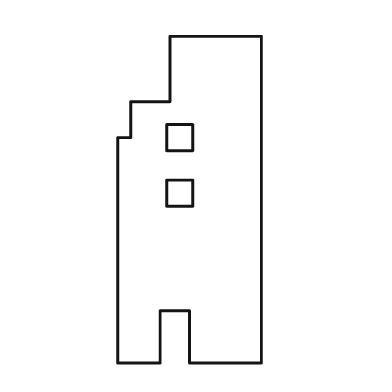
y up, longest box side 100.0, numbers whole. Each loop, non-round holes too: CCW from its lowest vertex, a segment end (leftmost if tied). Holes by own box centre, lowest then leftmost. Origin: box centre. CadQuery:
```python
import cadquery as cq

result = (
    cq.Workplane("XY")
    .moveTo(-22.0, -50.0)
    .lineTo(-9.0, -50.0)
    .lineTo(-9.0, -34.0)
    .lineTo(0.0, -34.0)
    .lineTo(0.0, -50.0)
    .lineTo(22.0, -50.0)
    .lineTo(22.0, 50.0)
    .lineTo(-6.0, 50.0)
    .lineTo(-6.0, 30.0)
    .lineTo(-18.0, 30.0)
    .lineTo(-18.0, 19.0)
    .lineTo(-22.0, 19.0)
    .close()
    .moveTo(-7.0, -2.0)
    .lineTo(1.0, -2.0)
    .lineTo(1.0, 6.0)
    .lineTo(-7.0, 6.0)
    .close()
    .moveTo(-7.0, 15.0)
    .lineTo(1.0, 15.0)
    .lineTo(1.0, 23.0)
    .lineTo(-7.0, 23.0)
    .close()
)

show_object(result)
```